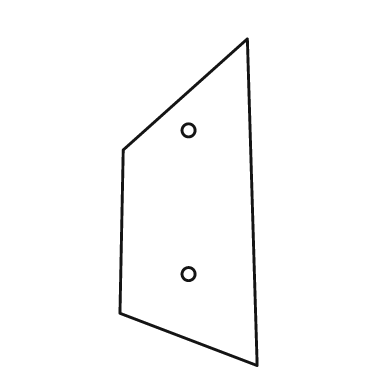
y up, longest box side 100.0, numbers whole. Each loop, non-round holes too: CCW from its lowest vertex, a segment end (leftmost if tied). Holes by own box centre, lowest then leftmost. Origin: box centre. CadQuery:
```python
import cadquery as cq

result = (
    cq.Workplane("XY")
    .moveTo(21.0, -50.0)
    .lineTo(18.0, 50.0)
    .lineTo(-20.0, 16.0)
    .lineTo(-21.0, -34.0)
    .close()
    .moveTo(0.0, -22.0)
    .circle(2.0)
    .moveTo(0.0, 22.0)
    .circle(2.0)
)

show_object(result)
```